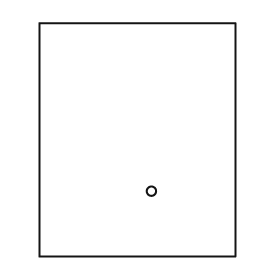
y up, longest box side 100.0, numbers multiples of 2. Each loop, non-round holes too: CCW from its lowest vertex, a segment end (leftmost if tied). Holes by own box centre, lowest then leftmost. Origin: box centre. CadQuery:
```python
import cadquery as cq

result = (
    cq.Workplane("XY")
    .moveTo(-42.0, -50.0)
    .lineTo(42.0, -50.0)
    .lineTo(42.0, 50.0)
    .lineTo(-42.0, 50.0)
    .close()
    .moveTo(6.0, -22.0)
    .circle(2.0)
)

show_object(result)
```